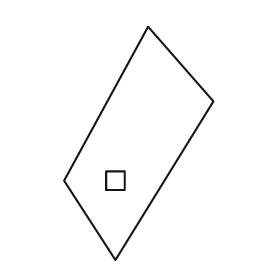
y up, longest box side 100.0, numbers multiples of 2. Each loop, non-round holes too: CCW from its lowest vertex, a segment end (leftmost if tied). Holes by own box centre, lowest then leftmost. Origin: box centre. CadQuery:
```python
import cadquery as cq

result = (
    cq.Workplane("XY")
    .moveTo(-10.0, -50.0)
    .lineTo(32.0, 18.0)
    .lineTo(4.0, 50.0)
    .lineTo(-32.0, -16.0)
    .close()
    .moveTo(-14.0, -20.0)
    .lineTo(-6.0, -20.0)
    .lineTo(-6.0, -12.0)
    .lineTo(-14.0, -12.0)
    .close()
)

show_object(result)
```